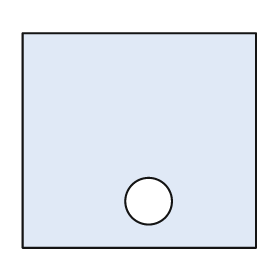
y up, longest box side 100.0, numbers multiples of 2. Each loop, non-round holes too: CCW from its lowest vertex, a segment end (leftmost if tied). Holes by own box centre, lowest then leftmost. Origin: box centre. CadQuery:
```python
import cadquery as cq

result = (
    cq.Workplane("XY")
    .moveTo(-50.0, -46.0)
    .lineTo(50.0, -46.0)
    .lineTo(50.0, 46.0)
    .lineTo(-50.0, 46.0)
    .close()
    .moveTo(4.0, -26.0)
    .circle(10.0)
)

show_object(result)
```